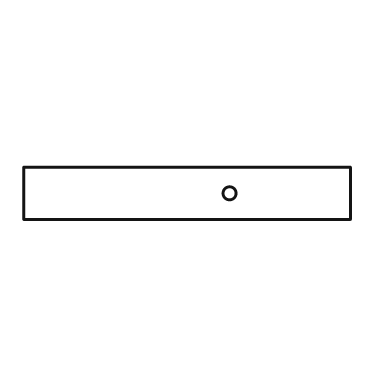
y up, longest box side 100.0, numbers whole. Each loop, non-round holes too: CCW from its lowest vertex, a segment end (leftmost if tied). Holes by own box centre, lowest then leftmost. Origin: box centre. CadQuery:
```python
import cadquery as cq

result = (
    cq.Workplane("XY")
    .moveTo(-50.0, -8.0)
    .lineTo(50.0, -8.0)
    .lineTo(50.0, 8.0)
    .lineTo(-50.0, 8.0)
    .close()
    .moveTo(13.0, 0.0)
    .circle(2.0)
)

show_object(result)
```